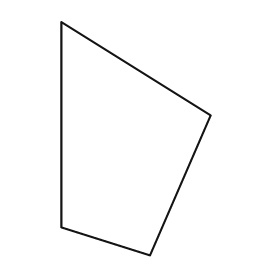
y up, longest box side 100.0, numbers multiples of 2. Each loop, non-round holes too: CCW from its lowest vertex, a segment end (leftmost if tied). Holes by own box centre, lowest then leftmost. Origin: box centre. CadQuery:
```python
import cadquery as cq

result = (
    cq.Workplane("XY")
    .moveTo(6.0, -50.0)
    .lineTo(32.0, 10.0)
    .lineTo(-32.0, 50.0)
    .lineTo(-32.0, -38.0)
    .close()
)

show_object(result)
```